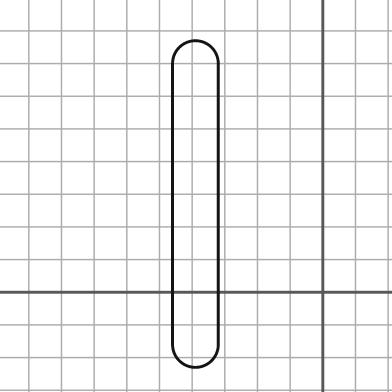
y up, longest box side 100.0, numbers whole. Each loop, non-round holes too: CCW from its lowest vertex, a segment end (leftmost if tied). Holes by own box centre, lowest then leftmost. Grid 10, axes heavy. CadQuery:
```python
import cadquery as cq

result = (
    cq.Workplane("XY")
    .moveTo(-46.0, -16.0)
    .threePointArc((-39.0, -23.0), (-32.0, -16.0))
    .lineTo(-32.0, 70.0)
    .threePointArc((-39.0, 77.0), (-46.0, 70.0))
    .close()
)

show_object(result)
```